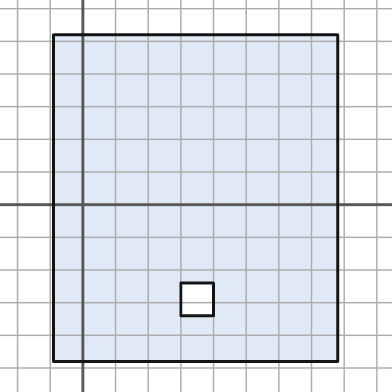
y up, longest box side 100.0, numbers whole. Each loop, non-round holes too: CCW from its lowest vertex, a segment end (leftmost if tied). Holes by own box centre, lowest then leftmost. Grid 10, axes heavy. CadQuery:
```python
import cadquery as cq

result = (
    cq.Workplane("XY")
    .moveTo(-9.0, -48.0)
    .lineTo(78.0, -48.0)
    .lineTo(78.0, 52.0)
    .lineTo(-9.0, 52.0)
    .close()
    .moveTo(30.0, -34.0)
    .lineTo(40.0, -34.0)
    .lineTo(40.0, -24.0)
    .lineTo(30.0, -24.0)
    .close()
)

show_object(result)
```